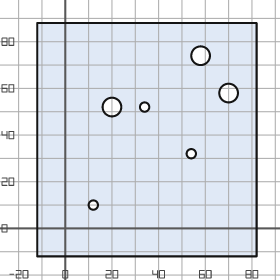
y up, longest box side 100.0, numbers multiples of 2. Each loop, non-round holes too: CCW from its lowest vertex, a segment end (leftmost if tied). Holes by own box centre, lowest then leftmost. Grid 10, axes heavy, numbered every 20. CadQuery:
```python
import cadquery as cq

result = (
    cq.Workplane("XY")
    .moveTo(-12.0, -12.0)
    .lineTo(82.0, -12.0)
    .lineTo(82.0, 88.0)
    .lineTo(-12.0, 88.0)
    .close()
    .moveTo(12.0, 10.0)
    .circle(2.0)
    .moveTo(54.0, 32.0)
    .circle(2.0)
    .moveTo(20.0, 52.0)
    .circle(4.0)
    .moveTo(34.0, 52.0)
    .circle(2.0)
    .moveTo(70.0, 58.0)
    .circle(4.0)
    .moveTo(58.0, 74.0)
    .circle(4.0)
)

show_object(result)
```